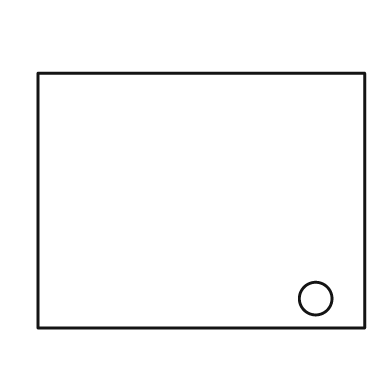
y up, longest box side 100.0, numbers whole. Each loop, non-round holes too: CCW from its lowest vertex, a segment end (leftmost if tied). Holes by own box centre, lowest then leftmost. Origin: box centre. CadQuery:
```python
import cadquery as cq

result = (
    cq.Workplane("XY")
    .moveTo(-50.0, -39.0)
    .lineTo(50.0, -39.0)
    .lineTo(50.0, 39.0)
    .lineTo(-50.0, 39.0)
    .close()
    .moveTo(35.0, -30.0)
    .circle(5.0)
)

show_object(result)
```